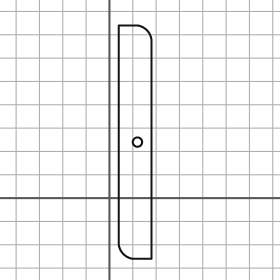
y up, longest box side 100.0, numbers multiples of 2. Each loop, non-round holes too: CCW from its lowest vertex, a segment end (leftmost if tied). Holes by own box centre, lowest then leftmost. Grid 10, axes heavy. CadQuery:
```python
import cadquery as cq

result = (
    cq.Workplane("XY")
    .moveTo(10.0, -26.0)
    .lineTo(18.0, -26.0)
    .lineTo(18.0, 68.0)
    .threePointArc((16.0, 72.0), (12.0, 74.0))
    .lineTo(4.0, 74.0)
    .lineTo(4.0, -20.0)
    .threePointArc((6.0, -24.0), (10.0, -26.0))
    .close()
    .moveTo(12.0, 24.0)
    .circle(2.0)
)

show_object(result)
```